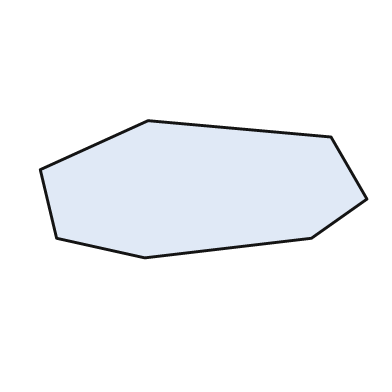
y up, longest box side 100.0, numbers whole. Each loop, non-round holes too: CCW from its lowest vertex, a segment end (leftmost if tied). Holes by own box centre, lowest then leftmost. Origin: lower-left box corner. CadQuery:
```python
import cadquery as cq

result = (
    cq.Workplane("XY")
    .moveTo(32.0, 0.0)
    .lineTo(83.0, 6.0)
    .lineTo(100.0, 18.0)
    .lineTo(89.0, 37.0)
    .lineTo(33.0, 42.0)
    .lineTo(0.0, 27.0)
    .lineTo(5.0, 6.0)
    .close()
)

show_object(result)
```